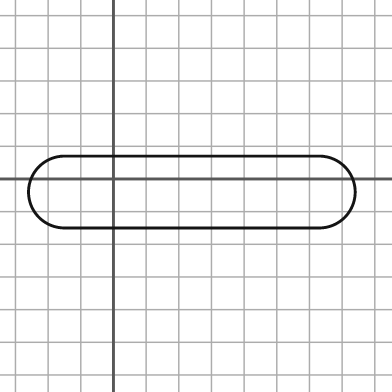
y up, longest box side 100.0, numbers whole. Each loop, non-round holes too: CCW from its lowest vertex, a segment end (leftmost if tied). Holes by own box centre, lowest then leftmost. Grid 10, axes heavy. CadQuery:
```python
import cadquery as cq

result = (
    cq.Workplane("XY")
    .moveTo(-15.0, -15.0)
    .lineTo(63.0, -15.0)
    .threePointArc((74.0, -4.0), (63.0, 7.0))
    .lineTo(-15.0, 7.0)
    .threePointArc((-26.0, -4.0), (-15.0, -15.0))
    .close()
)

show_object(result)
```